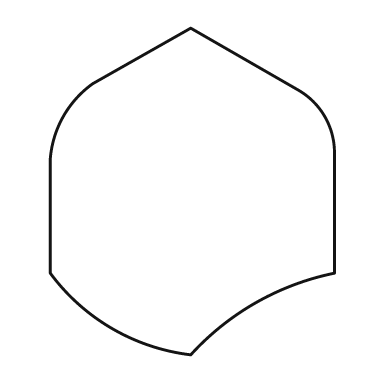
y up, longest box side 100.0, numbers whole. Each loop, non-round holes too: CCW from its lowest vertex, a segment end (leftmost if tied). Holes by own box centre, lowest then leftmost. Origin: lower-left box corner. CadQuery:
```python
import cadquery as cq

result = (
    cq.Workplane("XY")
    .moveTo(43.0, 0.0)
    .threePointArc((63.0, 16.0), (87.0, 25.0))
    .lineTo(87.0, 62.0)
    .threePointArc((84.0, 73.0), (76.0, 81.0))
    .lineTo(43.0, 100.0)
    .lineTo(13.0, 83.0)
    .threePointArc((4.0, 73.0), (0.0, 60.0))
    .lineTo(0.0, 25.0)
    .threePointArc((19.0, 8.0), (43.0, 0.0))
    .close()
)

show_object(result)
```